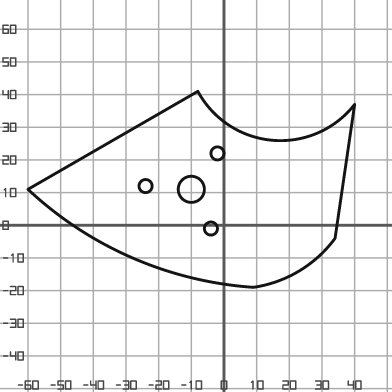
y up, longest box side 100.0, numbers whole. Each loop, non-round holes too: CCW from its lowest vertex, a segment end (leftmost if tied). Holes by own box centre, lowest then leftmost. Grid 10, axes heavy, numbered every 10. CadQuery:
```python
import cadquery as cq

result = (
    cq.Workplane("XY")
    .moveTo(9.0, -19.0)
    .threePointArc((23.0, -14.0), (34.0, -4.0))
    .lineTo(40.0, 37.0)
    .threePointArc((15.0, 26.0), (-8.0, 41.0))
    .lineTo(-60.0, 11.0)
    .threePointArc((-28.0, -10.0), (9.0, -19.0))
    .close()
    .moveTo(-4.0, -1.0)
    .circle(2.0)
    .moveTo(-10.0, 11.0)
    .circle(4.0)
    .moveTo(-24.0, 12.0)
    .circle(2.0)
    .moveTo(-2.0, 22.0)
    .circle(2.0)
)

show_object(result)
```